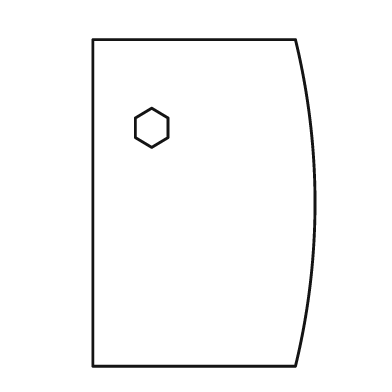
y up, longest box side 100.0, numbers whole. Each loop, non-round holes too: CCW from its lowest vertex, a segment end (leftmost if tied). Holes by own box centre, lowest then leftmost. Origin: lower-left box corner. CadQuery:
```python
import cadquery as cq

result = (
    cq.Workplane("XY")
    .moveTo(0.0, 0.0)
    .lineTo(62.0, 0.0)
    .threePointArc((68.0, 50.0), (62.0, 100.0))
    .lineTo(0.0, 100.0)
    .close()
    .moveTo(18.0, 67.0)
    .lineTo(23.0, 70.0)
    .lineTo(23.0, 76.0)
    .lineTo(18.0, 79.0)
    .lineTo(13.0, 76.0)
    .lineTo(13.0, 70.0)
    .close()
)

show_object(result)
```